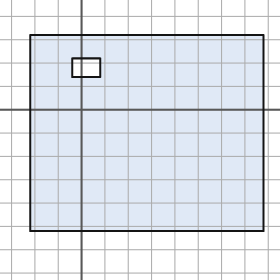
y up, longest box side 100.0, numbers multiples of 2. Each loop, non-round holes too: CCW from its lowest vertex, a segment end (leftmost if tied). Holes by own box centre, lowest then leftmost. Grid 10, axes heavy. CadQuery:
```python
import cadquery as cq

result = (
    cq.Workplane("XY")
    .moveTo(-22.0, -52.0)
    .lineTo(78.0, -52.0)
    .lineTo(78.0, 32.0)
    .lineTo(-22.0, 32.0)
    .close()
    .moveTo(-4.0, 14.0)
    .lineTo(8.0, 14.0)
    .lineTo(8.0, 22.0)
    .lineTo(-4.0, 22.0)
    .close()
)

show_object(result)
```